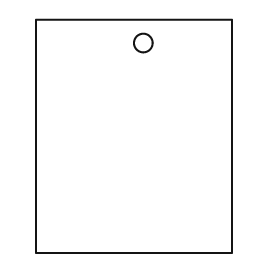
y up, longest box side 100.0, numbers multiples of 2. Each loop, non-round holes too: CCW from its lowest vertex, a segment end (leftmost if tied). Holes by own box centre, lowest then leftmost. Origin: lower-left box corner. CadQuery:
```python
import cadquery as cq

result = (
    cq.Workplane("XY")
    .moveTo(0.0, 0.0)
    .lineTo(84.0, 0.0)
    .lineTo(84.0, 100.0)
    .lineTo(0.0, 100.0)
    .close()
    .moveTo(46.0, 90.0)
    .circle(4.0)
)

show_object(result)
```